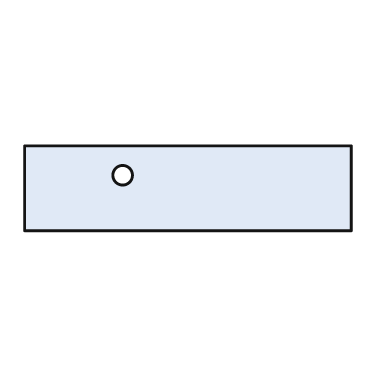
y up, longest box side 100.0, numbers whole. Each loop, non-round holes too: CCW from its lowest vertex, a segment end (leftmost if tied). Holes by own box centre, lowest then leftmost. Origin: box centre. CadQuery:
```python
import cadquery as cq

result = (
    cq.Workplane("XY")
    .moveTo(-50.0, -13.0)
    .lineTo(50.0, -13.0)
    .lineTo(50.0, 13.0)
    .lineTo(-50.0, 13.0)
    .close()
    .moveTo(-20.0, 4.0)
    .circle(3.0)
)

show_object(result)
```